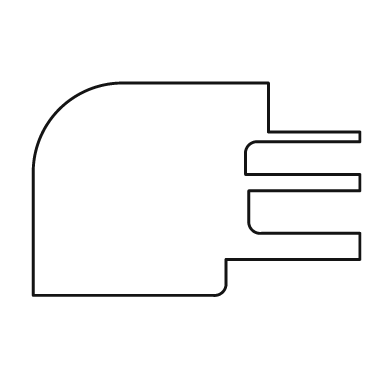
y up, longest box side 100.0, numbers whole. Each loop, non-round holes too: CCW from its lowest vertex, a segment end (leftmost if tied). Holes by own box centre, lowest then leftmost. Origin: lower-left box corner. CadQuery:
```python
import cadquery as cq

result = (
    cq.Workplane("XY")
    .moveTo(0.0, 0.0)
    .lineTo(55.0, 0.0)
    .threePointArc((58.0, 1.0), (59.0, 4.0))
    .lineTo(59.0, 11.0)
    .lineTo(100.0, 11.0)
    .lineTo(100.0, 19.0)
    .lineTo(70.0, 19.0)
    .threePointArc((67.0, 20.0), (66.0, 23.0))
    .lineTo(66.0, 32.0)
    .lineTo(100.0, 32.0)
    .lineTo(100.0, 37.0)
    .lineTo(65.0, 37.0)
    .lineTo(65.0, 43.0)
    .threePointArc((66.0, 46.0), (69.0, 47.0))
    .lineTo(100.0, 47.0)
    .lineTo(100.0, 50.0)
    .lineTo(72.0, 50.0)
    .lineTo(72.0, 65.0)
    .lineTo(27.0, 65.0)
    .threePointArc((8.0, 57.0), (0.0, 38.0))
    .close()
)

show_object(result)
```